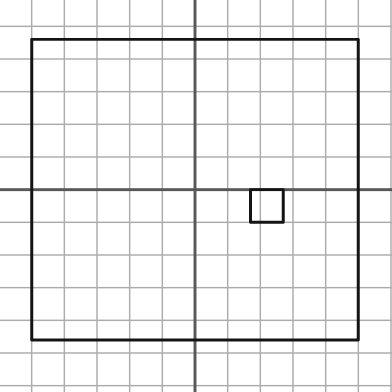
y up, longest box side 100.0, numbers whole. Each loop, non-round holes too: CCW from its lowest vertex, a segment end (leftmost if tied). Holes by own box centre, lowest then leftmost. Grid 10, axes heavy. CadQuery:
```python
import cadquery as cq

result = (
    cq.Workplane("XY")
    .moveTo(-50.0, -46.0)
    .lineTo(50.0, -46.0)
    .lineTo(50.0, 46.0)
    .lineTo(-50.0, 46.0)
    .close()
    .moveTo(17.0, -10.0)
    .lineTo(27.0, -10.0)
    .lineTo(27.0, 0.0)
    .lineTo(17.0, 0.0)
    .close()
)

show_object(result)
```